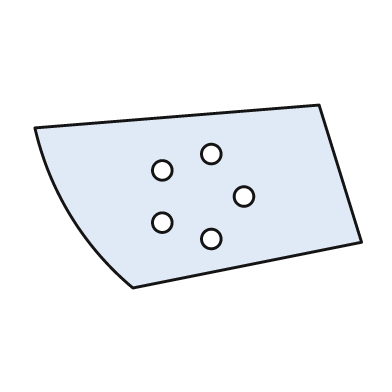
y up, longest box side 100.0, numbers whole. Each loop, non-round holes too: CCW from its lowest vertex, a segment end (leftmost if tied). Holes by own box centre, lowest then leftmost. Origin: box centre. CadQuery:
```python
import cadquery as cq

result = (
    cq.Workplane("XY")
    .moveTo(-20.0, -28.0)
    .lineTo(50.0, -14.0)
    .lineTo(37.0, 28.0)
    .lineTo(-50.0, 21.0)
    .threePointArc((-39.0, -6.0), (-20.0, -28.0))
    .close()
    .moveTo(4.0, -13.0)
    .circle(3.0)
    .moveTo(-11.0, -8.0)
    .circle(3.0)
    .moveTo(14.0, 0.0)
    .circle(3.0)
    .moveTo(-11.0, 8.0)
    .circle(3.0)
    .moveTo(4.0, 13.0)
    .circle(3.0)
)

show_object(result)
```